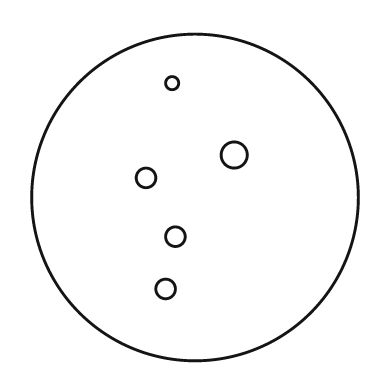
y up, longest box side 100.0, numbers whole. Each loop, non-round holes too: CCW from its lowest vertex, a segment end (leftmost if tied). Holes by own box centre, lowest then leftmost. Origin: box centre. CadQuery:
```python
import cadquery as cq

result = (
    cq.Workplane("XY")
    .moveTo(0.0, 0.0)
    .circle(50.0)
    .moveTo(-9.0, -28.0)
    .circle(3.0)
    .moveTo(-6.0, -12.0)
    .circle(3.0)
    .moveTo(-15.0, 6.0)
    .circle(3.0)
    .moveTo(12.0, 13.0)
    .circle(4.0)
    .moveTo(-7.0, 35.0)
    .circle(2.0)
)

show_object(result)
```